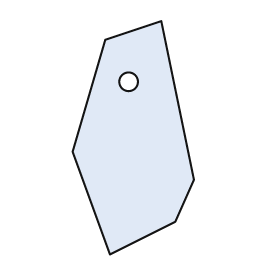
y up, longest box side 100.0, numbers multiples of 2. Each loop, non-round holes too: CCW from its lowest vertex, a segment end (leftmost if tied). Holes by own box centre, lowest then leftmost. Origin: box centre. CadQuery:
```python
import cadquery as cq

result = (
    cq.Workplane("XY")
    .moveTo(-10.0, -50.0)
    .lineTo(18.0, -36.0)
    .lineTo(26.0, -18.0)
    .lineTo(12.0, 50.0)
    .lineTo(-12.0, 42.0)
    .lineTo(-26.0, -6.0)
    .close()
    .moveTo(-2.0, 24.0)
    .circle(4.0)
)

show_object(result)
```